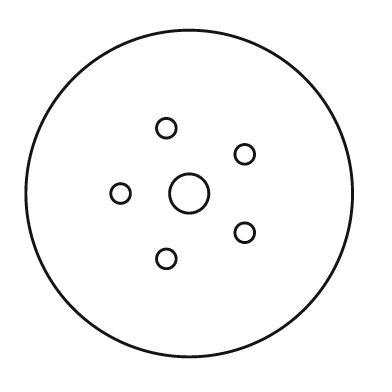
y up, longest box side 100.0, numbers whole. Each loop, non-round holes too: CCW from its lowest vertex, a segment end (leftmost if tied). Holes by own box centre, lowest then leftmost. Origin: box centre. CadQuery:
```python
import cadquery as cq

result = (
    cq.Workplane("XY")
    .moveTo(0.0, 0.0)
    .circle(50.0)
    .moveTo(-7.0, -20.0)
    .circle(3.0)
    .moveTo(17.0, -12.0)
    .circle(3.0)
    .moveTo(-21.0, 0.0)
    .circle(3.0)
    .moveTo(0.0, 0.0)
    .circle(6.0)
    .moveTo(17.0, 12.0)
    .circle(3.0)
    .moveTo(-7.0, 20.0)
    .circle(3.0)
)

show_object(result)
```